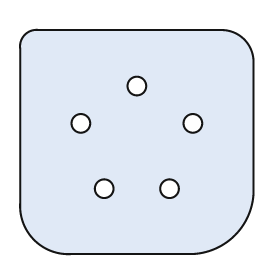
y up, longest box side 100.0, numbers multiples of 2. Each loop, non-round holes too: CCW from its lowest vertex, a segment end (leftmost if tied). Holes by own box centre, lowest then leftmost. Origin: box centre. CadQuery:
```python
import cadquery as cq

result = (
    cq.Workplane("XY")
    .moveTo(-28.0, -48.0)
    .lineTo(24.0, -48.0)
    .threePointArc((42.0, -40.0), (50.0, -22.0))
    .lineTo(50.0, 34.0)
    .threePointArc((46.0, 44.0), (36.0, 48.0))
    .lineTo(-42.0, 48.0)
    .threePointArc((-48.0, 46.0), (-50.0, 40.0))
    .lineTo(-50.0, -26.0)
    .threePointArc((-44.0, -42.0), (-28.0, -48.0))
    .close()
    .moveTo(-14.0, -20.0)
    .circle(4.0)
    .moveTo(14.0, -20.0)
    .circle(4.0)
    .moveTo(-24.0, 8.0)
    .circle(4.0)
    .moveTo(24.0, 8.0)
    .circle(4.0)
    .moveTo(0.0, 24.0)
    .circle(4.0)
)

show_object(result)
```